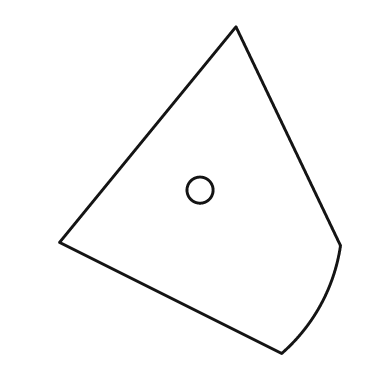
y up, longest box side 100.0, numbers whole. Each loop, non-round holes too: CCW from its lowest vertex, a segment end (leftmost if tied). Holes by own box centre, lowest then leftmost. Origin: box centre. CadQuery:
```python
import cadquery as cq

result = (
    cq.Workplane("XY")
    .moveTo(25.0, -50.0)
    .threePointArc((37.0, -35.0), (43.0, -17.0))
    .lineTo(11.0, 50.0)
    .lineTo(-43.0, -16.0)
    .close()
    .moveTo(0.0, 0.0)
    .circle(4.0)
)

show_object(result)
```